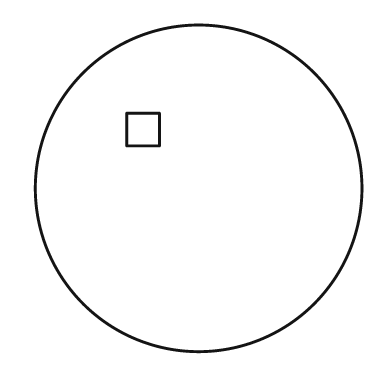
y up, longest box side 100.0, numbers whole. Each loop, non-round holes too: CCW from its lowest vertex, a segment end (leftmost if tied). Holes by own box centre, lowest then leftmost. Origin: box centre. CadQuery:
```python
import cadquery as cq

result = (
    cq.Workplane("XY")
    .moveTo(0.0, 0.0)
    .circle(50.0)
    .moveTo(-22.0, 13.0)
    .lineTo(-12.0, 13.0)
    .lineTo(-12.0, 23.0)
    .lineTo(-22.0, 23.0)
    .close()
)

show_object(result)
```